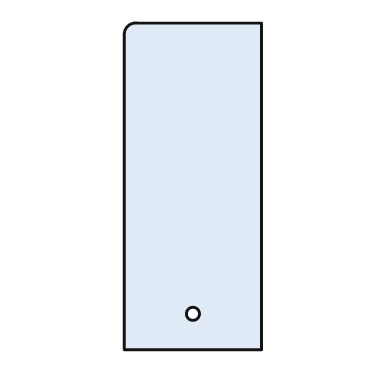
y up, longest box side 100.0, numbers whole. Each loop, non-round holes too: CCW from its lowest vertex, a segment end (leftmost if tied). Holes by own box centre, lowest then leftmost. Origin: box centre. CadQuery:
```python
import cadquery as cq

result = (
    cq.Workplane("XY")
    .moveTo(-21.0, -50.0)
    .lineTo(21.0, -50.0)
    .lineTo(21.0, 50.0)
    .lineTo(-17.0, 50.0)
    .threePointArc((-20.0, 49.0), (-21.0, 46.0))
    .close()
    .moveTo(0.0, -39.0)
    .circle(2.0)
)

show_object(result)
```